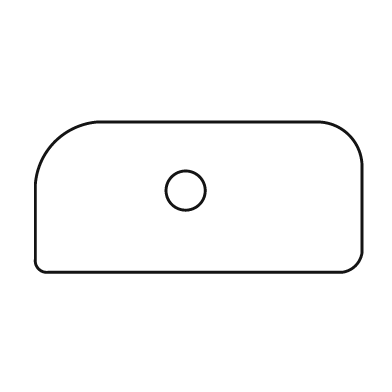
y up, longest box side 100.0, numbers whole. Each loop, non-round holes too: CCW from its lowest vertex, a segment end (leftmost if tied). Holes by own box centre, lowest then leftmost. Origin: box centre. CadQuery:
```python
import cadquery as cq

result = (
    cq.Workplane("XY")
    .moveTo(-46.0, -23.0)
    .lineTo(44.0, -23.0)
    .threePointArc((48.0, -21.0), (50.0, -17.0))
    .lineTo(50.0, 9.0)
    .threePointArc((46.0, 19.0), (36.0, 23.0))
    .lineTo(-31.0, 23.0)
    .threePointArc((-44.0, 17.0), (-50.0, 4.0))
    .lineTo(-50.0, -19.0)
    .threePointArc((-49.0, -22.0), (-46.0, -23.0))
    .close()
    .moveTo(-4.0, 2.0)
    .circle(6.0)
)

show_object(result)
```